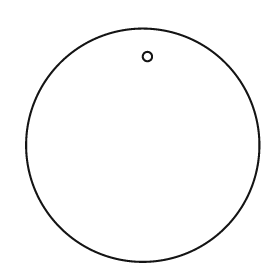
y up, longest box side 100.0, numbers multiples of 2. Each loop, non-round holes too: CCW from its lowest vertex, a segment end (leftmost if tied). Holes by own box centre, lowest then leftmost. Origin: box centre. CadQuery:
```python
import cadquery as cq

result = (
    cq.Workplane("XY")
    .moveTo(0.0, 0.0)
    .circle(50.0)
    .moveTo(2.0, 38.0)
    .circle(2.0)
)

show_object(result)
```